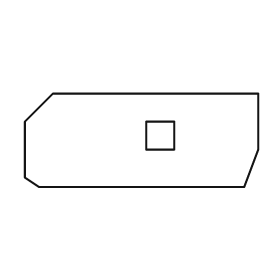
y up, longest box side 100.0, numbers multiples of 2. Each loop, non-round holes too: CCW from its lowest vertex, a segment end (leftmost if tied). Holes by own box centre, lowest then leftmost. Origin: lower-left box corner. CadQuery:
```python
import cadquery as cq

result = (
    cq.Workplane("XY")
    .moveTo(6.0, 0.0)
    .lineTo(94.0, 0.0)
    .lineTo(100.0, 16.0)
    .lineTo(100.0, 40.0)
    .lineTo(12.0, 40.0)
    .lineTo(0.0, 28.0)
    .lineTo(0.0, 4.0)
    .close()
    .moveTo(52.0, 16.0)
    .lineTo(64.0, 16.0)
    .lineTo(64.0, 28.0)
    .lineTo(52.0, 28.0)
    .close()
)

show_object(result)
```